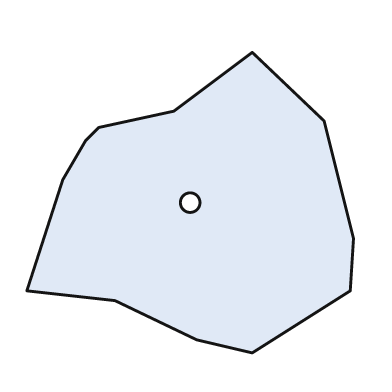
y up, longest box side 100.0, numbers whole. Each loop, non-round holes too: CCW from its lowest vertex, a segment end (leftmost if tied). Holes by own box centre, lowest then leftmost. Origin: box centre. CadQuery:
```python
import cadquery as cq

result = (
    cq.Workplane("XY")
    .moveTo(19.0, -46.0)
    .lineTo(49.0, -27.0)
    .lineTo(50.0, -11.0)
    .lineTo(41.0, 25.0)
    .lineTo(19.0, 46.0)
    .lineTo(-5.0, 28.0)
    .lineTo(-28.0, 23.0)
    .lineTo(-32.0, 19.0)
    .lineTo(-39.0, 7.0)
    .lineTo(-50.0, -27.0)
    .lineTo(-23.0, -30.0)
    .lineTo(2.0, -42.0)
    .close()
    .moveTo(0.0, 0.0)
    .circle(3.0)
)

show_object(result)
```